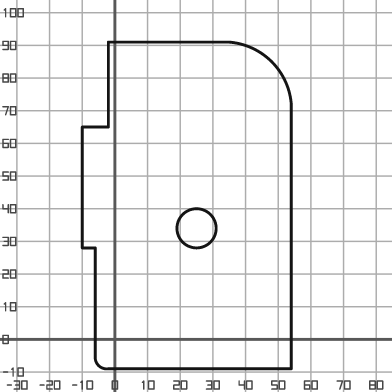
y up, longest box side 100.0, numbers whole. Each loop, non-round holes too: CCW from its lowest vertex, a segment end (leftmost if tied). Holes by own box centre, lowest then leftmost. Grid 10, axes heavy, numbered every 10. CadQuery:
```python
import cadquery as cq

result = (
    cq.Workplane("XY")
    .moveTo(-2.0, -9.0)
    .lineTo(54.0, -9.0)
    .lineTo(54.0, 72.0)
    .threePointArc((48.0, 85.0), (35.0, 91.0))
    .lineTo(-2.0, 91.0)
    .lineTo(-2.0, 65.0)
    .lineTo(-10.0, 65.0)
    .lineTo(-10.0, 28.0)
    .lineTo(-6.0, 28.0)
    .lineTo(-6.0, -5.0)
    .threePointArc((-5.0, -8.0), (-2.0, -9.0))
    .close()
    .moveTo(25.0, 34.0)
    .circle(6.0)
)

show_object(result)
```